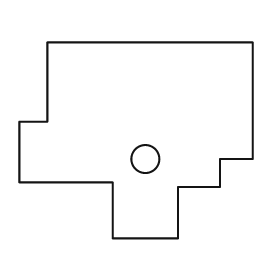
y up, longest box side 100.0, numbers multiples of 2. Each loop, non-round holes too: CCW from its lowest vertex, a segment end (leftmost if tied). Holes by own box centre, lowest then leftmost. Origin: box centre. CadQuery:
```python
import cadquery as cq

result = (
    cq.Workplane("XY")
    .moveTo(-10.0, -42.0)
    .lineTo(18.0, -42.0)
    .lineTo(18.0, -20.0)
    .lineTo(36.0, -20.0)
    .lineTo(36.0, -8.0)
    .lineTo(50.0, -8.0)
    .lineTo(50.0, 42.0)
    .lineTo(-38.0, 42.0)
    .lineTo(-38.0, 8.0)
    .lineTo(-50.0, 8.0)
    .lineTo(-50.0, -18.0)
    .lineTo(-10.0, -18.0)
    .close()
    .moveTo(4.0, -8.0)
    .circle(6.0)
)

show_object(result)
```